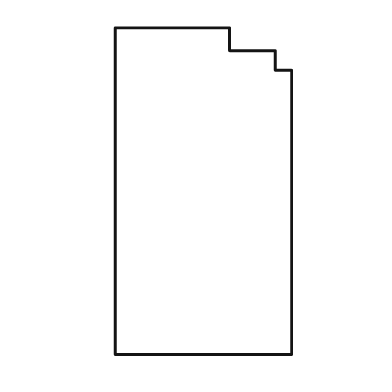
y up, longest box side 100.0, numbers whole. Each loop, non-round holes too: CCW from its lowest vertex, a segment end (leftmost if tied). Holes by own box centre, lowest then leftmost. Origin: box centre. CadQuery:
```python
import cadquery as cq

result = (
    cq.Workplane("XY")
    .moveTo(-27.0, -50.0)
    .lineTo(27.0, -50.0)
    .lineTo(27.0, 37.0)
    .lineTo(22.0, 37.0)
    .lineTo(22.0, 43.0)
    .lineTo(8.0, 43.0)
    .lineTo(8.0, 50.0)
    .lineTo(-27.0, 50.0)
    .close()
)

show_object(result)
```